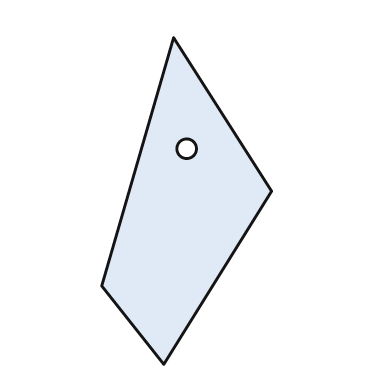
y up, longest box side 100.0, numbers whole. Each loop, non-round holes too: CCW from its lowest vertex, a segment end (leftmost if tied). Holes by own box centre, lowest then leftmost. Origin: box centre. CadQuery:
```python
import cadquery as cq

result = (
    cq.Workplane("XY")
    .moveTo(-7.0, -50.0)
    .lineTo(26.0, 3.0)
    .lineTo(-4.0, 50.0)
    .lineTo(-26.0, -26.0)
    .close()
    .moveTo(0.0, 16.0)
    .circle(3.0)
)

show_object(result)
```